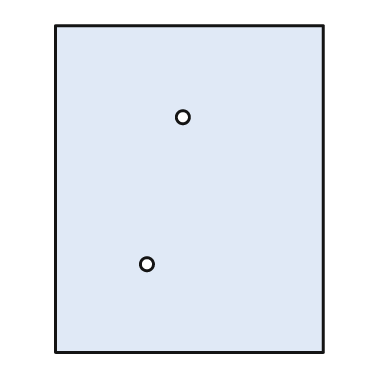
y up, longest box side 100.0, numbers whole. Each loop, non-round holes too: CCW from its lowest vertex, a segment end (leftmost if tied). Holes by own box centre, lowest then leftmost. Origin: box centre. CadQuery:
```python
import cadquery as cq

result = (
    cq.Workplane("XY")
    .moveTo(-41.0, -50.0)
    .lineTo(41.0, -50.0)
    .lineTo(41.0, 50.0)
    .lineTo(-41.0, 50.0)
    .close()
    .moveTo(-13.0, -23.0)
    .circle(2.0)
    .moveTo(-2.0, 22.0)
    .circle(2.0)
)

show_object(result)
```